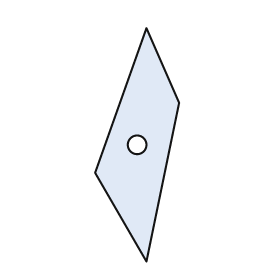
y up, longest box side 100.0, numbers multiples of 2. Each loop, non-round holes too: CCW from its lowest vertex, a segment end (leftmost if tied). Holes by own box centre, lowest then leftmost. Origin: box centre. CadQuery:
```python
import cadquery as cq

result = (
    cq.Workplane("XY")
    .moveTo(4.0, -50.0)
    .lineTo(18.0, 18.0)
    .lineTo(4.0, 50.0)
    .lineTo(-18.0, -12.0)
    .close()
    .moveTo(0.0, 0.0)
    .circle(4.0)
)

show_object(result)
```